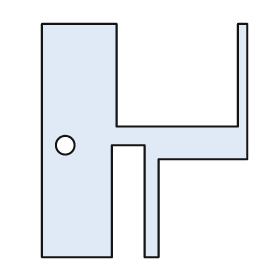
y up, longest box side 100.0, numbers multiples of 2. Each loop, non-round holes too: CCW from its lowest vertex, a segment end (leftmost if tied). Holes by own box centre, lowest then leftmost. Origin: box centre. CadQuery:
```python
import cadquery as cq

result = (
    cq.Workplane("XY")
    .moveTo(-44.0, -50.0)
    .lineTo(-14.0, -50.0)
    .lineTo(-14.0, -2.0)
    .lineTo(0.0, -2.0)
    .lineTo(0.0, -50.0)
    .lineTo(6.0, -50.0)
    .lineTo(6.0, -8.0)
    .lineTo(44.0, -8.0)
    .lineTo(44.0, 50.0)
    .lineTo(40.0, 50.0)
    .lineTo(40.0, 6.0)
    .lineTo(-12.0, 6.0)
    .lineTo(-12.0, 50.0)
    .lineTo(-44.0, 50.0)
    .close()
    .moveTo(-34.0, -2.0)
    .circle(4.0)
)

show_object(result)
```